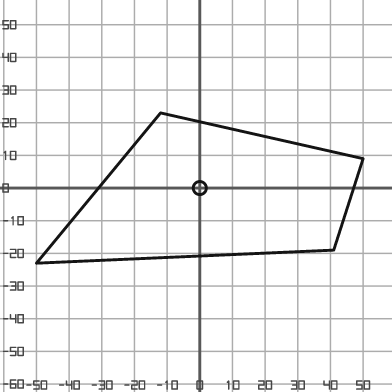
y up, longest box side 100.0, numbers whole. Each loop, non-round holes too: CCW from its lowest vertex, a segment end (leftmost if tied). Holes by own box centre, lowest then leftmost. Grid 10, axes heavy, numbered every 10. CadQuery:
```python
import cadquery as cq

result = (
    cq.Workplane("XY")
    .moveTo(-50.0, -23.0)
    .lineTo(41.0, -19.0)
    .lineTo(50.0, 9.0)
    .lineTo(-12.0, 23.0)
    .close()
    .moveTo(0.0, 0.0)
    .circle(2.0)
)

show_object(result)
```